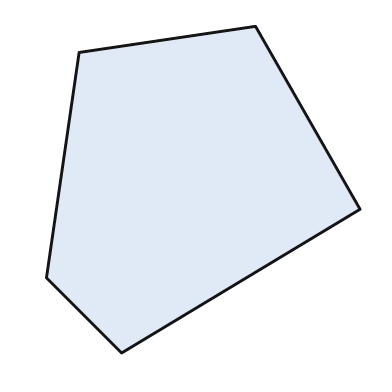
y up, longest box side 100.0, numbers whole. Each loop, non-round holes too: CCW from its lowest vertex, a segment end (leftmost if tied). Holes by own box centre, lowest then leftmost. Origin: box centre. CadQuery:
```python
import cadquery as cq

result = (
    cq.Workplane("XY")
    .moveTo(-25.0, -50.0)
    .lineTo(48.0, -6.0)
    .lineTo(16.0, 50.0)
    .lineTo(-38.0, 42.0)
    .lineTo(-48.0, -27.0)
    .close()
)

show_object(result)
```